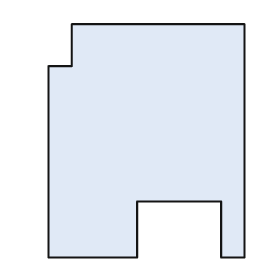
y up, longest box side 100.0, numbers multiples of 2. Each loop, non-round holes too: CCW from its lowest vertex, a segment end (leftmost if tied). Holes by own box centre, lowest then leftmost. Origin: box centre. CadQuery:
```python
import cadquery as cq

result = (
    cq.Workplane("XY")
    .moveTo(-42.0, -50.0)
    .lineTo(-4.0, -50.0)
    .lineTo(-4.0, -26.0)
    .lineTo(32.0, -26.0)
    .lineTo(32.0, -50.0)
    .lineTo(42.0, -50.0)
    .lineTo(42.0, 50.0)
    .lineTo(-32.0, 50.0)
    .lineTo(-32.0, 32.0)
    .lineTo(-42.0, 32.0)
    .close()
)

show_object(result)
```